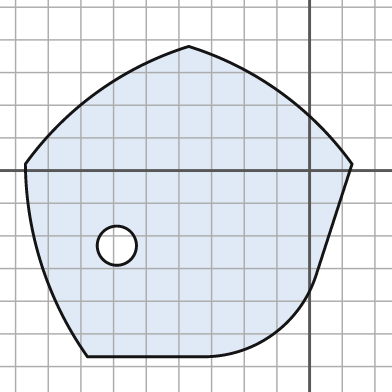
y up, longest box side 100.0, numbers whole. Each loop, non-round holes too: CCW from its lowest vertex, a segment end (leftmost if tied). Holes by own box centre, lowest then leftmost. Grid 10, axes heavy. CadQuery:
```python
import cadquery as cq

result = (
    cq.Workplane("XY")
    .moveTo(-68.0, -57.0)
    .lineTo(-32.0, -57.0)
    .threePointArc((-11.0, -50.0), (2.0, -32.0))
    .lineTo(13.0, 2.0)
    .threePointArc((-9.0, 24.0), (-37.0, 38.0))
    .threePointArc((-65.0, 24.0), (-87.0, 2.0))
    .threePointArc((-82.0, -29.0), (-68.0, -57.0))
    .close()
    .moveTo(-59.0, -23.0)
    .circle(6.0)
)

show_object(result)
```